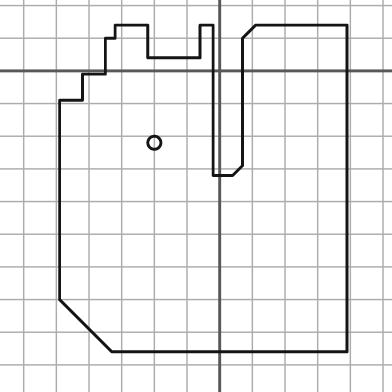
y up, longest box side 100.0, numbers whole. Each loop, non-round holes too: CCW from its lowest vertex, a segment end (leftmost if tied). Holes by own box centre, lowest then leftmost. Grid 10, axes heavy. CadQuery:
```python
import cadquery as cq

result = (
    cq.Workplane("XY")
    .moveTo(-33.0, -86.0)
    .lineTo(39.0, -86.0)
    .lineTo(39.0, 14.0)
    .lineTo(11.0, 14.0)
    .lineTo(7.0, 10.0)
    .lineTo(7.0, -29.0)
    .lineTo(4.0, -32.0)
    .lineTo(-2.0, -32.0)
    .lineTo(-2.0, 14.0)
    .lineTo(-6.0, 14.0)
    .lineTo(-6.0, 4.0)
    .lineTo(-22.0, 4.0)
    .lineTo(-22.0, 14.0)
    .lineTo(-32.0, 14.0)
    .lineTo(-32.0, 10.0)
    .lineTo(-35.0, 10.0)
    .lineTo(-35.0, -1.0)
    .lineTo(-42.0, -1.0)
    .lineTo(-42.0, -9.0)
    .lineTo(-49.0, -9.0)
    .lineTo(-49.0, -70.0)
    .close()
    .moveTo(-20.0, -22.0)
    .circle(2.0)
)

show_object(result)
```